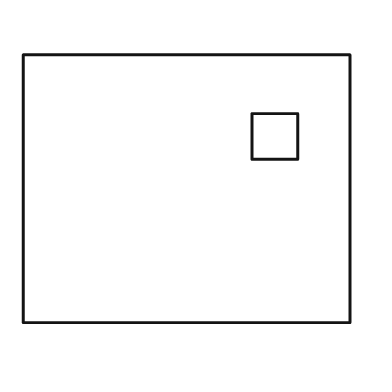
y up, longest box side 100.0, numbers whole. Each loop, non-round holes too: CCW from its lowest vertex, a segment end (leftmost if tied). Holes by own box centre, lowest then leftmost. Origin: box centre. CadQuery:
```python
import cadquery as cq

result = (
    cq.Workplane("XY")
    .moveTo(-50.0, -41.0)
    .lineTo(50.0, -41.0)
    .lineTo(50.0, 41.0)
    .lineTo(-50.0, 41.0)
    .close()
    .moveTo(20.0, 9.0)
    .lineTo(34.0, 9.0)
    .lineTo(34.0, 23.0)
    .lineTo(20.0, 23.0)
    .close()
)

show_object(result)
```